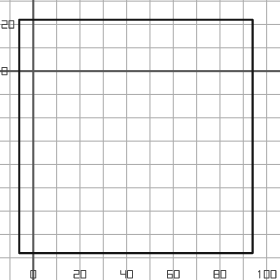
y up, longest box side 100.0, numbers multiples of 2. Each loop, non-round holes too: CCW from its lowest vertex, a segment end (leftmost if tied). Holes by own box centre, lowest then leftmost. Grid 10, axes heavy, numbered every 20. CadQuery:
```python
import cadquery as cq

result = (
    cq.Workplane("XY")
    .moveTo(-6.0, -78.0)
    .lineTo(94.0, -78.0)
    .lineTo(94.0, 22.0)
    .lineTo(-6.0, 22.0)
    .close()
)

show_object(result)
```